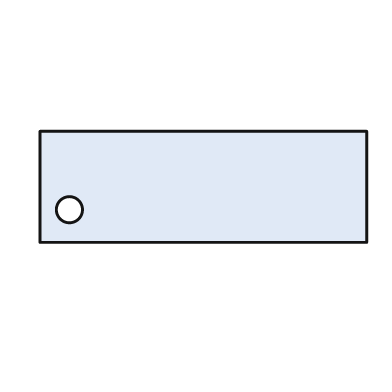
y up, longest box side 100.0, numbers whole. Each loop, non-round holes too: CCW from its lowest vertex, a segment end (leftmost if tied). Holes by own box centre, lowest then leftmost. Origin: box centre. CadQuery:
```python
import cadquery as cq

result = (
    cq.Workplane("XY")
    .moveTo(-50.0, -17.0)
    .lineTo(50.0, -17.0)
    .lineTo(50.0, 17.0)
    .lineTo(-50.0, 17.0)
    .close()
    .moveTo(-41.0, -7.0)
    .circle(4.0)
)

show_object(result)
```